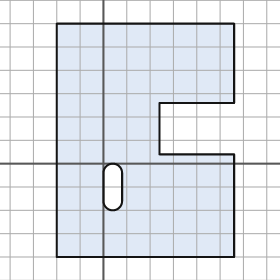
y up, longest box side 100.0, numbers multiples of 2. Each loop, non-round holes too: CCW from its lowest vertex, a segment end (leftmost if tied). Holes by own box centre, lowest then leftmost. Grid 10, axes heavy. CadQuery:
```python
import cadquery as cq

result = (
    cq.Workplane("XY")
    .moveTo(-20.0, -40.0)
    .lineTo(56.0, -40.0)
    .lineTo(56.0, 4.0)
    .lineTo(24.0, 4.0)
    .lineTo(24.0, 26.0)
    .lineTo(56.0, 26.0)
    .lineTo(56.0, 60.0)
    .lineTo(-20.0, 60.0)
    .close()
    .moveTo(0.0, -16.0)
    .threePointArc((4.0, -20.0), (8.0, -16.0))
    .lineTo(8.0, -4.0)
    .threePointArc((4.0, 0.0), (0.0, -4.0))
    .close()
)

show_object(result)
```